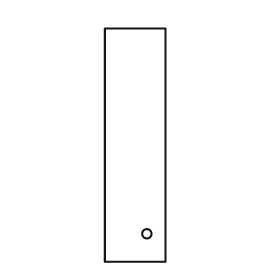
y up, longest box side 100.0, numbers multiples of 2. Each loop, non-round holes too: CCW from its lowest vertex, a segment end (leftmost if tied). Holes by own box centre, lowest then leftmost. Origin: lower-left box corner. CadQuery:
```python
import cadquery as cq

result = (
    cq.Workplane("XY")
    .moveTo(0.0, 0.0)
    .lineTo(26.0, 0.0)
    .lineTo(26.0, 100.0)
    .lineTo(0.0, 100.0)
    .close()
    .moveTo(18.0, 12.0)
    .circle(2.0)
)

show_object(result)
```